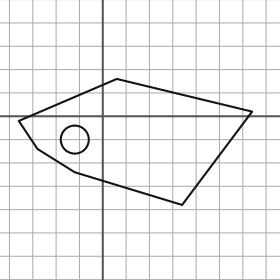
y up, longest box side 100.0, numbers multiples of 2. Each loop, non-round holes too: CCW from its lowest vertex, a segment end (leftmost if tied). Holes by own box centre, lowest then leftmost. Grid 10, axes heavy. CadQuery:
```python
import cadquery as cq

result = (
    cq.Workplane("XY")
    .moveTo(34.0, -38.0)
    .lineTo(64.0, 2.0)
    .lineTo(6.0, 16.0)
    .lineTo(-36.0, -2.0)
    .lineTo(-28.0, -14.0)
    .lineTo(-12.0, -24.0)
    .close()
    .moveTo(-12.0, -10.0)
    .circle(6.0)
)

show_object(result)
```